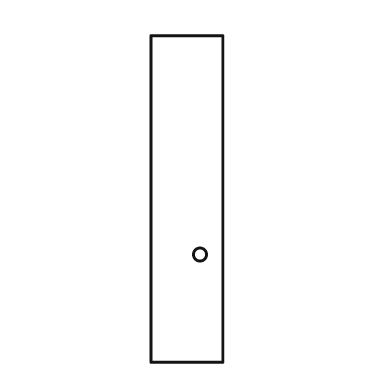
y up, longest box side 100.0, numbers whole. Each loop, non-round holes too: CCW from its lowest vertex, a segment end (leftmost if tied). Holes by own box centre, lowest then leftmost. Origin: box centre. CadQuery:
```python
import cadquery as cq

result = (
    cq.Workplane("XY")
    .moveTo(-11.0, -50.0)
    .lineTo(11.0, -50.0)
    .lineTo(11.0, 50.0)
    .lineTo(-11.0, 50.0)
    .close()
    .moveTo(4.0, -17.0)
    .circle(2.0)
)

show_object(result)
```